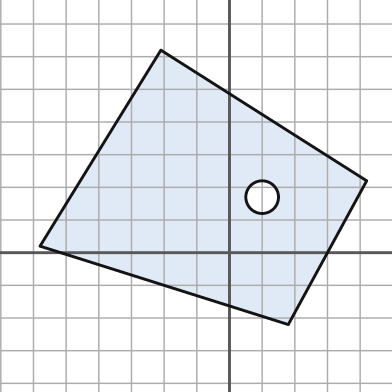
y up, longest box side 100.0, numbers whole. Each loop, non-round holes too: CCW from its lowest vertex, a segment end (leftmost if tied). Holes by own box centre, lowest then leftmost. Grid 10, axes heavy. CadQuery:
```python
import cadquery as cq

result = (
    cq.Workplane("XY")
    .moveTo(18.0, -22.0)
    .lineTo(42.0, 22.0)
    .lineTo(-21.0, 62.0)
    .lineTo(-58.0, 2.0)
    .close()
    .moveTo(10.0, 17.0)
    .circle(5.0)
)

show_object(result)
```